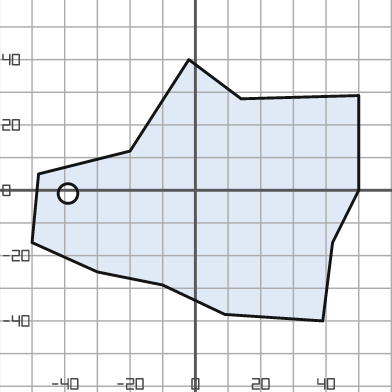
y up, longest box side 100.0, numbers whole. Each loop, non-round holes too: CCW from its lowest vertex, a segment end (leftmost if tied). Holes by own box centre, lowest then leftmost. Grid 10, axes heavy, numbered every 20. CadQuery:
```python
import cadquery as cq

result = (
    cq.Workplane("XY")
    .moveTo(39.0, -40.0)
    .lineTo(42.0, -16.0)
    .lineTo(50.0, 0.0)
    .lineTo(50.0, 29.0)
    .lineTo(14.0, 28.0)
    .lineTo(-2.0, 40.0)
    .lineTo(-20.0, 12.0)
    .lineTo(-48.0, 5.0)
    .lineTo(-50.0, -16.0)
    .lineTo(-30.0, -25.0)
    .lineTo(-10.0, -29.0)
    .lineTo(9.0, -38.0)
    .close()
    .moveTo(-39.0, -1.0)
    .circle(3.0)
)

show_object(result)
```